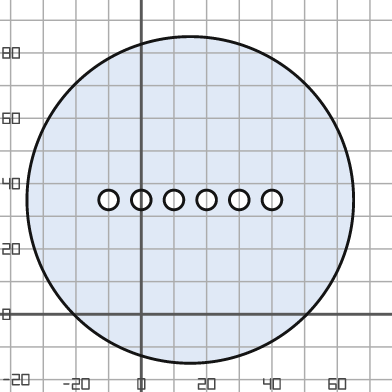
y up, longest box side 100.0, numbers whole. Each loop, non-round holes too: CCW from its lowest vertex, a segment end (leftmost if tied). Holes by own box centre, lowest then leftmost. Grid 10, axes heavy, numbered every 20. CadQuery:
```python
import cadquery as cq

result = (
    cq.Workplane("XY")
    .moveTo(15.0, 35.0)
    .circle(50.0)
    .moveTo(-10.0, 35.0)
    .circle(3.0)
    .moveTo(0.0, 35.0)
    .circle(3.0)
    .moveTo(10.0, 35.0)
    .circle(3.0)
    .moveTo(20.0, 35.0)
    .circle(3.0)
    .moveTo(30.0, 35.0)
    .circle(3.0)
    .moveTo(40.0, 35.0)
    .circle(3.0)
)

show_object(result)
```